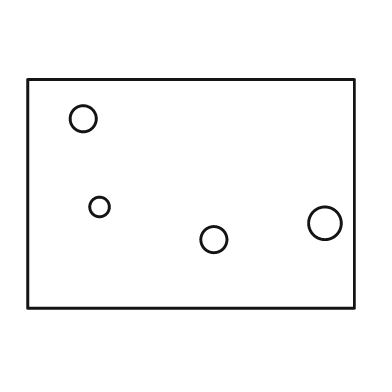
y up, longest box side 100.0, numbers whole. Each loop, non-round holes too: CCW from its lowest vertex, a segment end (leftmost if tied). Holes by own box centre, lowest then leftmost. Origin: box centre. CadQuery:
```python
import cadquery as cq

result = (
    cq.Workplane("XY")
    .moveTo(-50.0, -35.0)
    .lineTo(50.0, -35.0)
    .lineTo(50.0, 35.0)
    .lineTo(-50.0, 35.0)
    .close()
    .moveTo(7.0, -14.0)
    .circle(4.0)
    .moveTo(41.0, -9.0)
    .circle(5.0)
    .moveTo(-28.0, -4.0)
    .circle(3.0)
    .moveTo(-33.0, 23.0)
    .circle(4.0)
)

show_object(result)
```